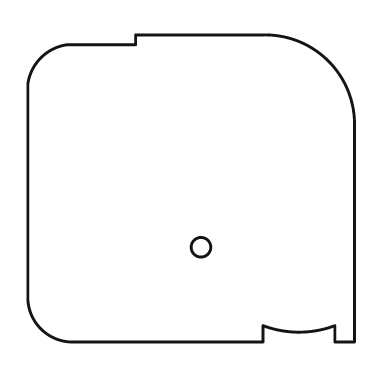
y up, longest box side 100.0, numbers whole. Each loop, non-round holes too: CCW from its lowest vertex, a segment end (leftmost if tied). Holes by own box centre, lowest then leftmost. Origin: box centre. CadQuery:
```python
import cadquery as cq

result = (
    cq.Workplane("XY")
    .moveTo(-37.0, -47.0)
    .lineTo(22.0, -47.0)
    .lineTo(22.0, -42.0)
    .threePointArc((33.0, -44.0), (44.0, -42.0))
    .lineTo(44.0, -47.0)
    .lineTo(50.0, -47.0)
    .lineTo(50.0, 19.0)
    .threePointArc((42.0, 39.0), (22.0, 47.0))
    .lineTo(-17.0, 47.0)
    .lineTo(-17.0, 44.0)
    .lineTo(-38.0, 44.0)
    .threePointArc((-46.0, 40.0), (-50.0, 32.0))
    .lineTo(-50.0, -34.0)
    .threePointArc((-46.0, -43.0), (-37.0, -47.0))
    .close()
    .moveTo(3.0, -18.0)
    .circle(3.0)
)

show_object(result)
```